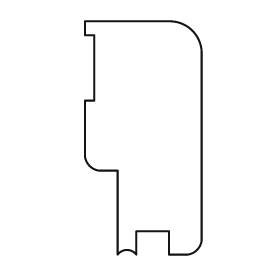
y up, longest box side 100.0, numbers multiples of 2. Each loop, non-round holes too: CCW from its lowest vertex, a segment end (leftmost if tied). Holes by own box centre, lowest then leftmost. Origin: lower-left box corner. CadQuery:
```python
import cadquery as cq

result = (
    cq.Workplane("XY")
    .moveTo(14.0, 0.0)
    .threePointArc((18.0, 2.0), (22.0, 0.0))
    .lineTo(22.0, 10.0)
    .lineTo(36.0, 10.0)
    .lineTo(36.0, 0.0)
    .lineTo(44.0, 0.0)
    .threePointArc((48.0, 2.0), (50.0, 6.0))
    .lineTo(50.0, 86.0)
    .threePointArc((46.0, 96.0), (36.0, 100.0))
    .lineTo(0.0, 100.0)
    .lineTo(0.0, 94.0)
    .lineTo(4.0, 94.0)
    .lineTo(4.0, 66.0)
    .lineTo(0.0, 66.0)
    .lineTo(0.0, 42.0)
    .threePointArc((2.0, 38.0), (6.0, 36.0))
    .lineTo(14.0, 36.0)
    .close()
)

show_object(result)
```